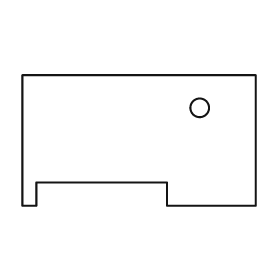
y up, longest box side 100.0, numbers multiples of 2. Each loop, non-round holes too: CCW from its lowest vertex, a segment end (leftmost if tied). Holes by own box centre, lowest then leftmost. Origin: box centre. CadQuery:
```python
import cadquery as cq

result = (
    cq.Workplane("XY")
    .moveTo(-50.0, -28.0)
    .lineTo(-44.0, -28.0)
    .lineTo(-44.0, -18.0)
    .lineTo(12.0, -18.0)
    .lineTo(12.0, -28.0)
    .lineTo(50.0, -28.0)
    .lineTo(50.0, 28.0)
    .lineTo(-50.0, 28.0)
    .close()
    .moveTo(26.0, 14.0)
    .circle(4.0)
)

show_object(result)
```